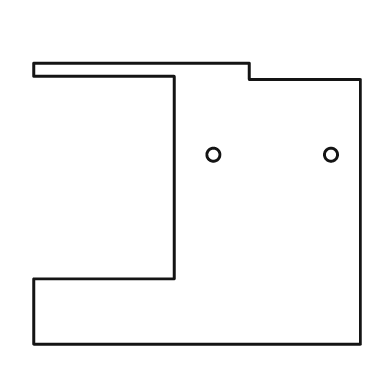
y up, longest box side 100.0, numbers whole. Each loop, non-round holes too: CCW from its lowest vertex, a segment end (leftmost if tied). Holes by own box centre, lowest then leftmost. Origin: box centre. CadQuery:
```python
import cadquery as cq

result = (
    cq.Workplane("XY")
    .moveTo(-50.0, -43.0)
    .lineTo(50.0, -43.0)
    .lineTo(50.0, 38.0)
    .lineTo(16.0, 38.0)
    .lineTo(16.0, 43.0)
    .lineTo(-50.0, 43.0)
    .lineTo(-50.0, 39.0)
    .lineTo(-7.0, 39.0)
    .lineTo(-7.0, -23.0)
    .lineTo(-50.0, -23.0)
    .close()
    .moveTo(5.0, 15.0)
    .circle(2.0)
    .moveTo(41.0, 15.0)
    .circle(2.0)
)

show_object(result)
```